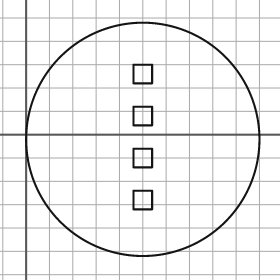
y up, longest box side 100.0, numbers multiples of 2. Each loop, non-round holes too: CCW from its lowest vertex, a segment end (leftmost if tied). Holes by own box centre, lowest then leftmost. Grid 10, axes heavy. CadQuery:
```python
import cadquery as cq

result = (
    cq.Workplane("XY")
    .moveTo(50.0, -2.0)
    .circle(50.0)
    .moveTo(46.0, -32.0)
    .lineTo(54.0, -32.0)
    .lineTo(54.0, -24.0)
    .lineTo(46.0, -24.0)
    .close()
    .moveTo(46.0, -14.0)
    .lineTo(54.0, -14.0)
    .lineTo(54.0, -6.0)
    .lineTo(46.0, -6.0)
    .close()
    .moveTo(46.0, 4.0)
    .lineTo(54.0, 4.0)
    .lineTo(54.0, 12.0)
    .lineTo(46.0, 12.0)
    .close()
    .moveTo(46.0, 22.0)
    .lineTo(54.0, 22.0)
    .lineTo(54.0, 30.0)
    .lineTo(46.0, 30.0)
    .close()
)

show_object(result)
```